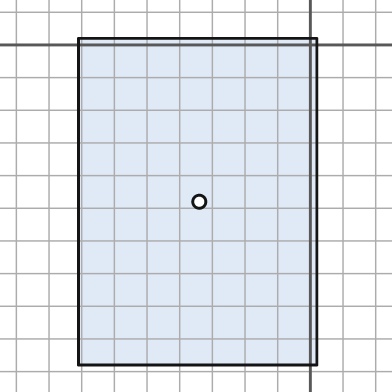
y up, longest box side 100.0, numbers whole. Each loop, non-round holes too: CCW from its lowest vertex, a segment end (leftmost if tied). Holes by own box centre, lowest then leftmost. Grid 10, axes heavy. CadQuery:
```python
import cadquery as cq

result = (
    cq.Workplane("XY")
    .moveTo(-71.0, -98.0)
    .lineTo(2.0, -98.0)
    .lineTo(2.0, 2.0)
    .lineTo(-71.0, 2.0)
    .close()
    .moveTo(-34.0, -48.0)
    .circle(2.0)
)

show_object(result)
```